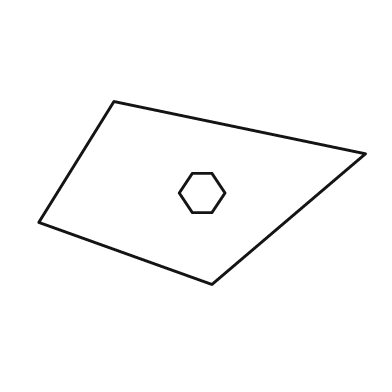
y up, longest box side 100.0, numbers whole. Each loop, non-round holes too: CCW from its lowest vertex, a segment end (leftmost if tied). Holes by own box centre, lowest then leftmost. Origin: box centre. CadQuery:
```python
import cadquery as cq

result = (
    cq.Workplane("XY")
    .moveTo(3.0, -28.0)
    .lineTo(50.0, 12.0)
    .lineTo(-27.0, 28.0)
    .lineTo(-50.0, -9.0)
    .close()
    .moveTo(-3.0, -6.0)
    .lineTo(3.0, -6.0)
    .lineTo(7.0, 0.0)
    .lineTo(3.0, 6.0)
    .lineTo(-3.0, 6.0)
    .lineTo(-7.0, 0.0)
    .close()
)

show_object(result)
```